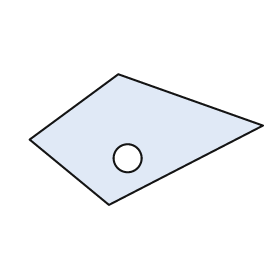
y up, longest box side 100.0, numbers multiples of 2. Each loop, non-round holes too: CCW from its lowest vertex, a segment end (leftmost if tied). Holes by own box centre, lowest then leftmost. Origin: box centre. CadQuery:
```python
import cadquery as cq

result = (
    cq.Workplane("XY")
    .moveTo(-16.0, -28.0)
    .lineTo(50.0, 6.0)
    .lineTo(-12.0, 28.0)
    .lineTo(-50.0, 0.0)
    .close()
    .moveTo(-8.0, -8.0)
    .circle(6.0)
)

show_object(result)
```